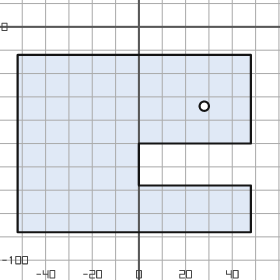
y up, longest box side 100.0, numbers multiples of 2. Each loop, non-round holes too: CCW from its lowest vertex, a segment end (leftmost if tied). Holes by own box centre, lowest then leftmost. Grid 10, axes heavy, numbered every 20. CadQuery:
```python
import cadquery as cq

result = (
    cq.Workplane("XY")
    .moveTo(-52.0, -88.0)
    .lineTo(48.0, -88.0)
    .lineTo(48.0, -68.0)
    .lineTo(0.0, -68.0)
    .lineTo(0.0, -50.0)
    .lineTo(48.0, -50.0)
    .lineTo(48.0, -12.0)
    .lineTo(-52.0, -12.0)
    .close()
    .moveTo(28.0, -34.0)
    .circle(2.0)
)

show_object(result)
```